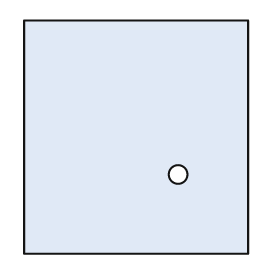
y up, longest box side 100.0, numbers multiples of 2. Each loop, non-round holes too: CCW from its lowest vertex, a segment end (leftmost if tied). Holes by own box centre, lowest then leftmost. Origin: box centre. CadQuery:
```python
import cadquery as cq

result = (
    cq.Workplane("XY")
    .moveTo(-48.0, -50.0)
    .lineTo(48.0, -50.0)
    .lineTo(48.0, 50.0)
    .lineTo(-48.0, 50.0)
    .close()
    .moveTo(18.0, -16.0)
    .circle(4.0)
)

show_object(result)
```